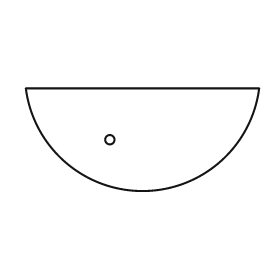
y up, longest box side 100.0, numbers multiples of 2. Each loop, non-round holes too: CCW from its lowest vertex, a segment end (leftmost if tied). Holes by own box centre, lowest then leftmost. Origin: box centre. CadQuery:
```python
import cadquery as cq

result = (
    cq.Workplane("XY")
    .moveTo(-50.0, 22.0)
    .threePointArc((0.0, -22.0), (50.0, 22.0))
    .close()
    .moveTo(-14.0, 0.0)
    .circle(2.0)
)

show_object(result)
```